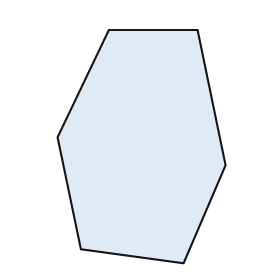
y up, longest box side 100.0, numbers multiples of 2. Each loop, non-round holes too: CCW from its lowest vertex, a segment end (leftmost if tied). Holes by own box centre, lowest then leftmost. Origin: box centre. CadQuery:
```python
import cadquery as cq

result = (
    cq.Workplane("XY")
    .moveTo(18.0, -50.0)
    .lineTo(36.0, -8.0)
    .lineTo(24.0, 50.0)
    .lineTo(-14.0, 50.0)
    .lineTo(-36.0, 4.0)
    .lineTo(-26.0, -44.0)
    .close()
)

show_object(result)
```